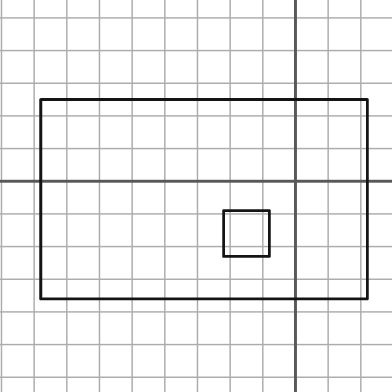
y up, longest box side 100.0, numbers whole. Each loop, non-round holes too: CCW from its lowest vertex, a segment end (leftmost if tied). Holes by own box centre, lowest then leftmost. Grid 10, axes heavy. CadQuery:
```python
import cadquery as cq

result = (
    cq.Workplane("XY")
    .moveTo(-78.0, -36.0)
    .lineTo(22.0, -36.0)
    .lineTo(22.0, 25.0)
    .lineTo(-78.0, 25.0)
    .close()
    .moveTo(-22.0, -23.0)
    .lineTo(-8.0, -23.0)
    .lineTo(-8.0, -9.0)
    .lineTo(-22.0, -9.0)
    .close()
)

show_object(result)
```